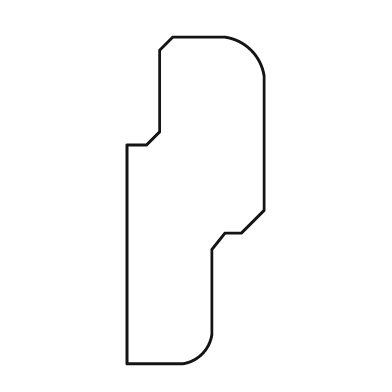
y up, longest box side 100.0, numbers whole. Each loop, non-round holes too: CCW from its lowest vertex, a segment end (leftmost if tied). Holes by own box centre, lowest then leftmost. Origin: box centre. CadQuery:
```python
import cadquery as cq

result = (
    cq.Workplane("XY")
    .moveTo(-21.0, -50.0)
    .lineTo(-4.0, -50.0)
    .threePointArc((2.0, -47.0), (5.0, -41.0))
    .lineTo(5.0, -15.0)
    .lineTo(9.0, -10.0)
    .lineTo(14.0, -10.0)
    .lineTo(21.0, -3.0)
    .lineTo(21.0, 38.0)
    .threePointArc((17.0, 46.0), (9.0, 50.0))
    .lineTo(-7.0, 50.0)
    .lineTo(-11.0, 46.0)
    .lineTo(-11.0, 21.0)
    .lineTo(-15.0, 17.0)
    .lineTo(-21.0, 17.0)
    .close()
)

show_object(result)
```